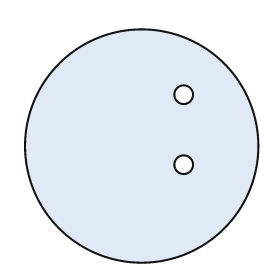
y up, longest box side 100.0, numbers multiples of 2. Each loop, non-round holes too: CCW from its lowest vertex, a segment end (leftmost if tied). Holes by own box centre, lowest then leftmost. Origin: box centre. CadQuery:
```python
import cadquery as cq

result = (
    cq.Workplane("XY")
    .moveTo(0.0, 0.0)
    .circle(50.0)
    .moveTo(18.0, -8.0)
    .circle(4.0)
    .moveTo(18.0, 22.0)
    .circle(4.0)
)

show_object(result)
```